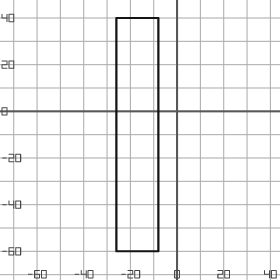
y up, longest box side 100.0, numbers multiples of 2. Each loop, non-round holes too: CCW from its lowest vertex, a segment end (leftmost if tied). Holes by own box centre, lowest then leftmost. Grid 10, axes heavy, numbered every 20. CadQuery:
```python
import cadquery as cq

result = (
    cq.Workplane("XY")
    .moveTo(-26.0, -60.0)
    .lineTo(-8.0, -60.0)
    .lineTo(-8.0, 40.0)
    .lineTo(-26.0, 40.0)
    .close()
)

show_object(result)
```